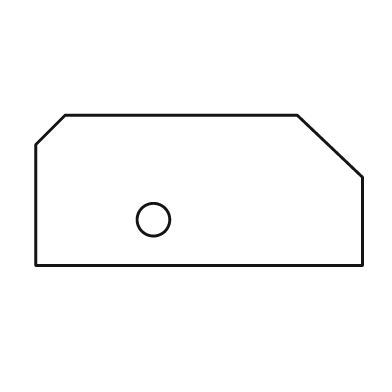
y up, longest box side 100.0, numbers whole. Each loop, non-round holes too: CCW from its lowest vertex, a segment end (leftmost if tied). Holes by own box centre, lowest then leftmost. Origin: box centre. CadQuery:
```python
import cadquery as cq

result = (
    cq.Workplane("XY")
    .moveTo(-50.0, -23.0)
    .lineTo(50.0, -23.0)
    .lineTo(50.0, 4.0)
    .lineTo(30.0, 23.0)
    .lineTo(-41.0, 23.0)
    .lineTo(-50.0, 14.0)
    .close()
    .moveTo(-14.0, -9.0)
    .circle(5.0)
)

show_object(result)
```